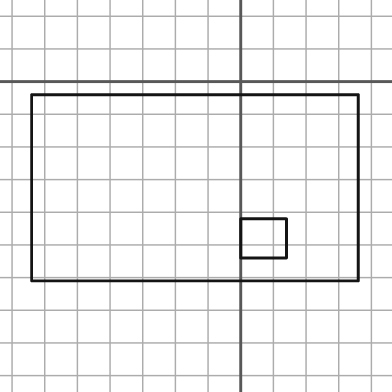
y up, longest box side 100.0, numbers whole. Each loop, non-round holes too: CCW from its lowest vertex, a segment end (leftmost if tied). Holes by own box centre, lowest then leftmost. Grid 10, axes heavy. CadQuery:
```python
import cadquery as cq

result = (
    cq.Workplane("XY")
    .moveTo(-64.0, -61.0)
    .lineTo(36.0, -61.0)
    .lineTo(36.0, -4.0)
    .lineTo(-64.0, -4.0)
    .close()
    .moveTo(0.0, -54.0)
    .lineTo(14.0, -54.0)
    .lineTo(14.0, -42.0)
    .lineTo(0.0, -42.0)
    .close()
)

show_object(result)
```